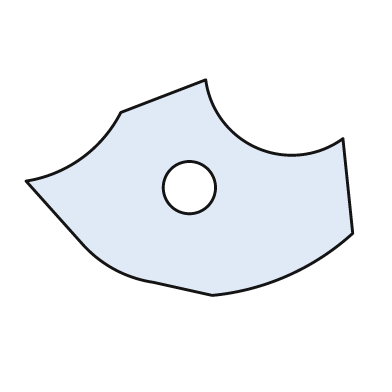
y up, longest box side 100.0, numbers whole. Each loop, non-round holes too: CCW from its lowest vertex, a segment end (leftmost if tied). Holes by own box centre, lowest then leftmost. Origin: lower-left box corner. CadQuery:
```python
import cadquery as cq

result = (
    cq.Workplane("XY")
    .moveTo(57.0, 0.0)
    .threePointArc((80.0, 6.0), (100.0, 19.0))
    .lineTo(97.0, 48.0)
    .threePointArc((71.0, 45.0), (55.0, 66.0))
    .lineTo(29.0, 56.0)
    .threePointArc((17.0, 42.0), (0.0, 35.0))
    .lineTo(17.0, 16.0)
    .threePointArc((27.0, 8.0), (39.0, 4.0))
    .close()
    .moveTo(50.0, 33.0)
    .circle(8.0)
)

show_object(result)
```